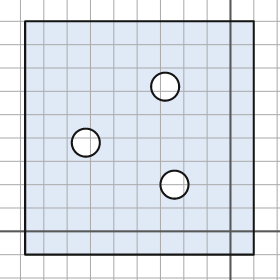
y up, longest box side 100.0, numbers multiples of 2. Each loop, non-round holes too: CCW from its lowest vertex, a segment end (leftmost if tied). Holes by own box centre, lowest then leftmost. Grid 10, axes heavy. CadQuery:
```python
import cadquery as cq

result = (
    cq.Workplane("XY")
    .moveTo(-88.0, -10.0)
    .lineTo(10.0, -10.0)
    .lineTo(10.0, 90.0)
    .lineTo(-88.0, 90.0)
    .close()
    .moveTo(-24.0, 20.0)
    .circle(6.0)
    .moveTo(-62.0, 38.0)
    .circle(6.0)
    .moveTo(-28.0, 62.0)
    .circle(6.0)
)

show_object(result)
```